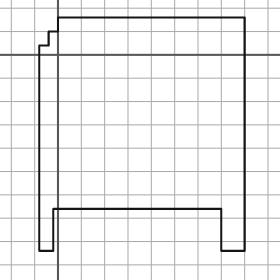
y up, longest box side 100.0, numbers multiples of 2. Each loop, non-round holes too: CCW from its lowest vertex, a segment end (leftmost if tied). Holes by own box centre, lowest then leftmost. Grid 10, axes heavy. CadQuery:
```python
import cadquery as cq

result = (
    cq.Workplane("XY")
    .moveTo(-8.0, -84.0)
    .lineTo(-2.0, -84.0)
    .lineTo(-2.0, -66.0)
    .lineTo(70.0, -66.0)
    .lineTo(70.0, -84.0)
    .lineTo(80.0, -84.0)
    .lineTo(80.0, 16.0)
    .lineTo(0.0, 16.0)
    .lineTo(0.0, 10.0)
    .lineTo(-4.0, 10.0)
    .lineTo(-4.0, 4.0)
    .lineTo(-8.0, 4.0)
    .close()
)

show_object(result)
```